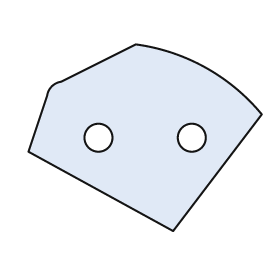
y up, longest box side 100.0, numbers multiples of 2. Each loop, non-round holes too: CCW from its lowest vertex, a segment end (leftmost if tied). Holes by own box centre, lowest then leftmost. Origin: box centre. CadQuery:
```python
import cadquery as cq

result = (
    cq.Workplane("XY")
    .moveTo(12.0, -40.0)
    .lineTo(50.0, 10.0)
    .threePointArc((26.0, 30.0), (-4.0, 40.0))
    .lineTo(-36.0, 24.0)
    .threePointArc((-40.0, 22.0), (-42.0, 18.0))
    .lineTo(-50.0, -6.0)
    .close()
    .moveTo(-20.0, 0.0)
    .circle(6.0)
    .moveTo(20.0, 0.0)
    .circle(6.0)
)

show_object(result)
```